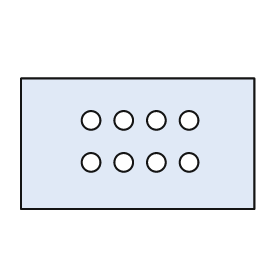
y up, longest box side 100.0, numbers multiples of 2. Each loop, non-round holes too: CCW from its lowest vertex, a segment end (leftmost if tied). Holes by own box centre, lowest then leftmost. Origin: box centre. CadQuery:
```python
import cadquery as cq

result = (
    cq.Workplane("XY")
    .moveTo(-50.0, -28.0)
    .lineTo(50.0, -28.0)
    .lineTo(50.0, 28.0)
    .lineTo(-50.0, 28.0)
    .close()
    .moveTo(-20.0, -8.0)
    .circle(4.0)
    .moveTo(-6.0, -8.0)
    .circle(4.0)
    .moveTo(8.0, -8.0)
    .circle(4.0)
    .moveTo(22.0, -8.0)
    .circle(4.0)
    .moveTo(-20.0, 10.0)
    .circle(4.0)
    .moveTo(-6.0, 10.0)
    .circle(4.0)
    .moveTo(8.0, 10.0)
    .circle(4.0)
    .moveTo(22.0, 10.0)
    .circle(4.0)
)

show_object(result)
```